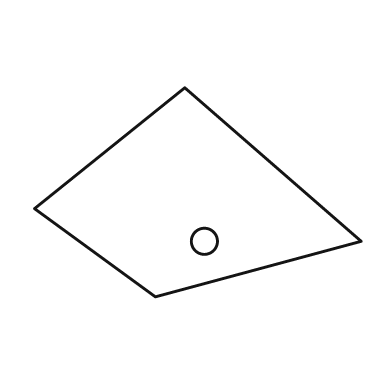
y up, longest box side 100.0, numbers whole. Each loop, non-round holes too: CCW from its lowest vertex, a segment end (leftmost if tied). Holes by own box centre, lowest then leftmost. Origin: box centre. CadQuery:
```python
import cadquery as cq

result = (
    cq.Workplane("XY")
    .moveTo(-13.0, -32.0)
    .lineTo(50.0, -15.0)
    .lineTo(-4.0, 32.0)
    .lineTo(-50.0, -5.0)
    .close()
    .moveTo(2.0, -15.0)
    .circle(4.0)
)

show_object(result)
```